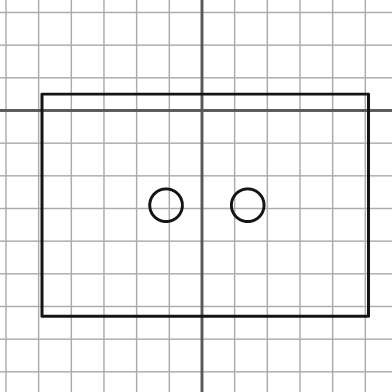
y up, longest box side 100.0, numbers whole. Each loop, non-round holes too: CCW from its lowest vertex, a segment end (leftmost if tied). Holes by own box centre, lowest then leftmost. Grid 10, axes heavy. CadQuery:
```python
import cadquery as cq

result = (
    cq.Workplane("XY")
    .moveTo(-49.0, -63.0)
    .lineTo(51.0, -63.0)
    .lineTo(51.0, 5.0)
    .lineTo(-49.0, 5.0)
    .close()
    .moveTo(-11.0, -29.0)
    .circle(5.0)
    .moveTo(14.0, -29.0)
    .circle(5.0)
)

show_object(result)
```